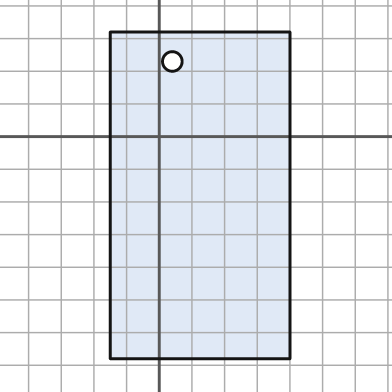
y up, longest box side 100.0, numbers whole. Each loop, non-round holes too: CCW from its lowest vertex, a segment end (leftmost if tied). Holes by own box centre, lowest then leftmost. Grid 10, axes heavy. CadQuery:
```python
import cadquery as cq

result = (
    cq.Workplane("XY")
    .moveTo(-15.0, -68.0)
    .lineTo(40.0, -68.0)
    .lineTo(40.0, 32.0)
    .lineTo(-15.0, 32.0)
    .close()
    .moveTo(4.0, 23.0)
    .circle(3.0)
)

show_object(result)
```